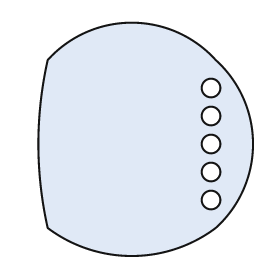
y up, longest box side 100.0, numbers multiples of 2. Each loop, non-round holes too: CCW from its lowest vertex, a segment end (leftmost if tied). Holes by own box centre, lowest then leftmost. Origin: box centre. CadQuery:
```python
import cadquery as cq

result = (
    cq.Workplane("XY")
    .moveTo(-42.0, -38.0)
    .threePointArc((-6.0, -50.0), (30.0, -38.0))
    .threePointArc((46.0, -2.0), (30.0, 34.0))
    .threePointArc((-6.0, 50.0), (-42.0, 34.0))
    .threePointArc((-46.0, -2.0), (-42.0, -38.0))
    .close()
    .moveTo(28.0, -26.0)
    .circle(4.0)
    .moveTo(28.0, -14.0)
    .circle(4.0)
    .moveTo(28.0, -2.0)
    .circle(4.0)
    .moveTo(28.0, 10.0)
    .circle(4.0)
    .moveTo(28.0, 22.0)
    .circle(4.0)
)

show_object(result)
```